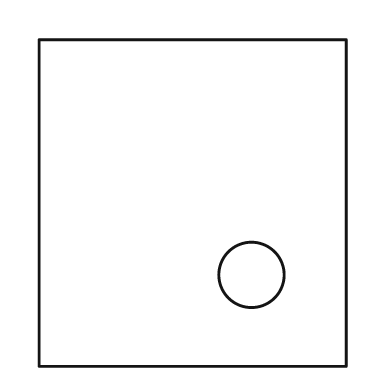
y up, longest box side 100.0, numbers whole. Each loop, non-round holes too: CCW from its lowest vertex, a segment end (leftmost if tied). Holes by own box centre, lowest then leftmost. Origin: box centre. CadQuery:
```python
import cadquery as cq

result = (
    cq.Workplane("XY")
    .moveTo(-47.0, -50.0)
    .lineTo(47.0, -50.0)
    .lineTo(47.0, 50.0)
    .lineTo(-47.0, 50.0)
    .close()
    .moveTo(18.0, -22.0)
    .circle(10.0)
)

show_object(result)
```